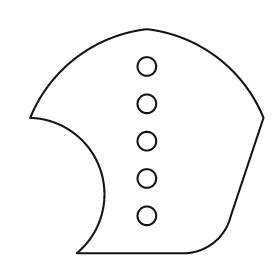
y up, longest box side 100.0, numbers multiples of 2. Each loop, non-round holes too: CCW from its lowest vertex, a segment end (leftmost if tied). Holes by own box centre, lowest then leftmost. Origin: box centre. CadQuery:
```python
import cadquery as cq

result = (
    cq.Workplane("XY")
    .moveTo(-30.0, -48.0)
    .lineTo(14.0, -48.0)
    .threePointArc((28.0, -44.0), (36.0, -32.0))
    .lineTo(50.0, 10.0)
    .threePointArc((30.0, 36.0), (0.0, 48.0))
    .threePointArc((-30.0, 36.0), (-50.0, 10.0))
    .threePointArc((-20.0, -12.0), (-30.0, -48.0))
    .close()
    .moveTo(0.0, -32.0)
    .circle(4.0)
    .moveTo(0.0, -16.0)
    .circle(4.0)
    .moveTo(0.0, 0.0)
    .circle(4.0)
    .moveTo(0.0, 16.0)
    .circle(4.0)
    .moveTo(0.0, 32.0)
    .circle(4.0)
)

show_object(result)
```